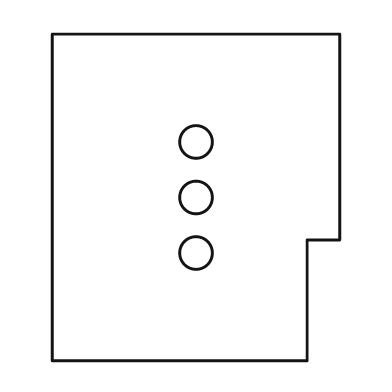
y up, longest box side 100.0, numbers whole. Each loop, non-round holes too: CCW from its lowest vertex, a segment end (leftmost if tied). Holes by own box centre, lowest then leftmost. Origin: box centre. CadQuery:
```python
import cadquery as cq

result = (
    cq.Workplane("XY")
    .moveTo(-44.0, -50.0)
    .lineTo(34.0, -50.0)
    .lineTo(34.0, -13.0)
    .lineTo(44.0, -13.0)
    .lineTo(44.0, 50.0)
    .lineTo(-44.0, 50.0)
    .close()
    .moveTo(0.0, -17.0)
    .circle(5.0)
    .moveTo(0.0, 0.0)
    .circle(5.0)
    .moveTo(0.0, 17.0)
    .circle(5.0)
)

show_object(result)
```